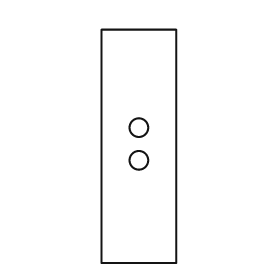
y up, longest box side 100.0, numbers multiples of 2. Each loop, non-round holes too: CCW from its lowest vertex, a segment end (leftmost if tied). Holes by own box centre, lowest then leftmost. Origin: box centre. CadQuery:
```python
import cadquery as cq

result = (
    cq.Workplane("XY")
    .moveTo(-16.0, -50.0)
    .lineTo(16.0, -50.0)
    .lineTo(16.0, 50.0)
    .lineTo(-16.0, 50.0)
    .close()
    .moveTo(0.0, -6.0)
    .circle(4.0)
    .moveTo(0.0, 8.0)
    .circle(4.0)
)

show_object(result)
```